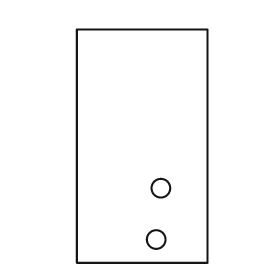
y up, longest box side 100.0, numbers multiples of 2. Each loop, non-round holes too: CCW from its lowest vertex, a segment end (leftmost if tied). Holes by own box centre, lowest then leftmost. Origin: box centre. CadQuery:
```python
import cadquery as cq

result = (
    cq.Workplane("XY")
    .moveTo(-28.0, -50.0)
    .lineTo(28.0, -50.0)
    .lineTo(28.0, 50.0)
    .lineTo(-28.0, 50.0)
    .close()
    .moveTo(6.0, -40.0)
    .circle(4.0)
    .moveTo(8.0, -18.0)
    .circle(4.0)
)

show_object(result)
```